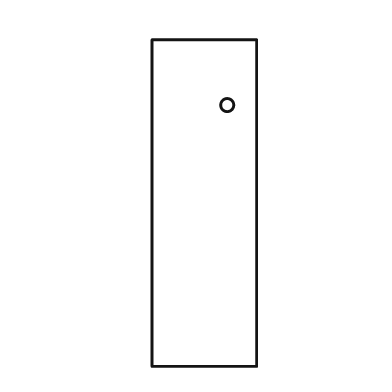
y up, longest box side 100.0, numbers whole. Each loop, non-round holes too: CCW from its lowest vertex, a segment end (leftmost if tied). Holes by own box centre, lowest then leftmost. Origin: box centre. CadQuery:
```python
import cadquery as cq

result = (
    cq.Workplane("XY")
    .moveTo(-16.0, -50.0)
    .lineTo(16.0, -50.0)
    .lineTo(16.0, 50.0)
    .lineTo(-16.0, 50.0)
    .close()
    .moveTo(7.0, 30.0)
    .circle(2.0)
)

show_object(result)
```